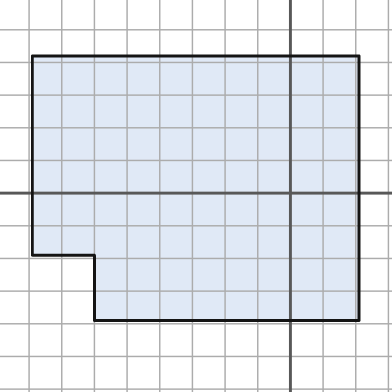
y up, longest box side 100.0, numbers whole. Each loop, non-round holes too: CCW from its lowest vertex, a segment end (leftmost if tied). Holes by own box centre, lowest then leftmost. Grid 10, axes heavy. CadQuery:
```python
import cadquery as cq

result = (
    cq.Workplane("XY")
    .moveTo(-60.0, -39.0)
    .lineTo(21.0, -39.0)
    .lineTo(21.0, 42.0)
    .lineTo(-79.0, 42.0)
    .lineTo(-79.0, -19.0)
    .lineTo(-60.0, -19.0)
    .close()
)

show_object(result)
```